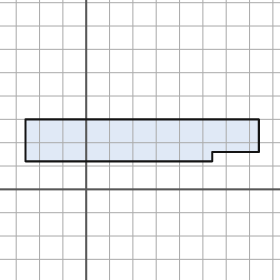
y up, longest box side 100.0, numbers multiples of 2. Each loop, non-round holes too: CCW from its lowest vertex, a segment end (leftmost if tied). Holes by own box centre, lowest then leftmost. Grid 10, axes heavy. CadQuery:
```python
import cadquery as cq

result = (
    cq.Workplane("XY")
    .moveTo(-26.0, 12.0)
    .lineTo(54.0, 12.0)
    .lineTo(54.0, 16.0)
    .lineTo(74.0, 16.0)
    .lineTo(74.0, 30.0)
    .lineTo(-26.0, 30.0)
    .close()
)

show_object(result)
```